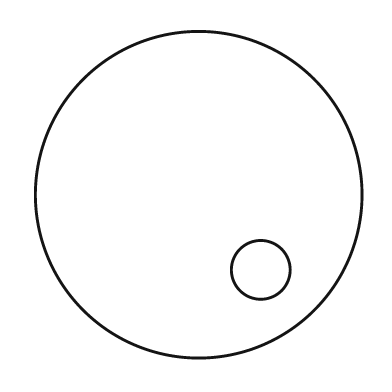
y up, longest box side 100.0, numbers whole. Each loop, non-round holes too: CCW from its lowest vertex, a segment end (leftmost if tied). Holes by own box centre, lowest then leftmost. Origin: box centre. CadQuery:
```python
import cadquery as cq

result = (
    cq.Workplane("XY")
    .moveTo(0.0, 0.0)
    .circle(50.0)
    .moveTo(19.0, -23.0)
    .circle(9.0)
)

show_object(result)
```